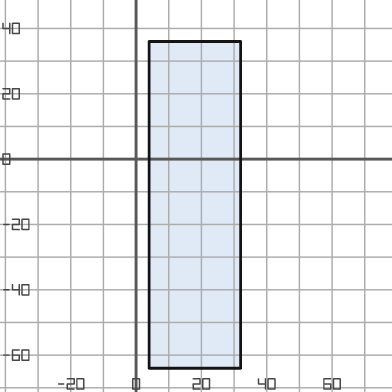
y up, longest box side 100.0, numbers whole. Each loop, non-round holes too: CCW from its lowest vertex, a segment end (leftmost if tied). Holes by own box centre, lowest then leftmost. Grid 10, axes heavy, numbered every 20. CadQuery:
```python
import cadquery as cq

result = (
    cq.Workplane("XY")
    .moveTo(4.0, -64.0)
    .lineTo(32.0, -64.0)
    .lineTo(32.0, 36.0)
    .lineTo(4.0, 36.0)
    .close()
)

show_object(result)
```